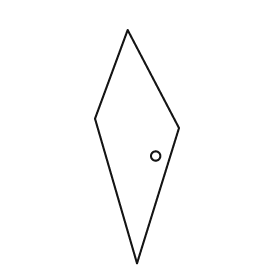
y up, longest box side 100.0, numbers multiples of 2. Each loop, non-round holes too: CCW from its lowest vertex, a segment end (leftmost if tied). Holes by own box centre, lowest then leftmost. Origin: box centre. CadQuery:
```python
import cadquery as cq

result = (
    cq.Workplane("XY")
    .moveTo(0.0, -50.0)
    .lineTo(18.0, 8.0)
    .lineTo(-4.0, 50.0)
    .lineTo(-18.0, 12.0)
    .close()
    .moveTo(8.0, -4.0)
    .circle(2.0)
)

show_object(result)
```